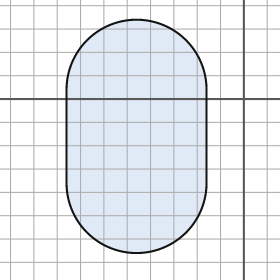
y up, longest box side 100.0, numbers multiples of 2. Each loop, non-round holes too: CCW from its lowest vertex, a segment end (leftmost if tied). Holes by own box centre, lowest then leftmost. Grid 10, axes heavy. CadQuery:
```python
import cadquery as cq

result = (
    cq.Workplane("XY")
    .moveTo(-76.0, -36.0)
    .threePointArc((-46.0, -66.0), (-16.0, -36.0))
    .lineTo(-16.0, 4.0)
    .threePointArc((-46.0, 34.0), (-76.0, 4.0))
    .close()
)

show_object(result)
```